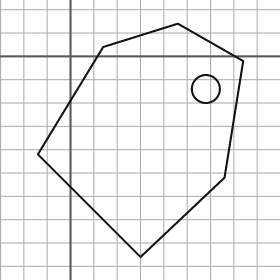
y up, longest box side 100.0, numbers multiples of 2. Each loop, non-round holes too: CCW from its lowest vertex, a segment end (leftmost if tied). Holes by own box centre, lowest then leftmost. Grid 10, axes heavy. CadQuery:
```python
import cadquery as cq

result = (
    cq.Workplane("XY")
    .moveTo(30.0, -86.0)
    .lineTo(66.0, -52.0)
    .lineTo(74.0, -2.0)
    .lineTo(46.0, 14.0)
    .lineTo(14.0, 4.0)
    .lineTo(-14.0, -42.0)
    .close()
    .moveTo(58.0, -14.0)
    .circle(6.0)
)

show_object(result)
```